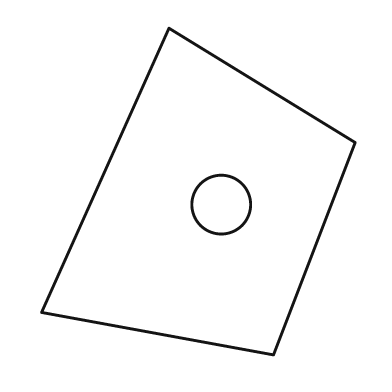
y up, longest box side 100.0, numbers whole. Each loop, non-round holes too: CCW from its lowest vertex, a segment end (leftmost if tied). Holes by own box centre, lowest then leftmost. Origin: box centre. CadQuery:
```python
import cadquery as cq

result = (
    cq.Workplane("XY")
    .moveTo(23.0, -50.0)
    .lineTo(48.0, 15.0)
    .lineTo(-9.0, 50.0)
    .lineTo(-48.0, -37.0)
    .close()
    .moveTo(7.0, -4.0)
    .circle(9.0)
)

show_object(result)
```